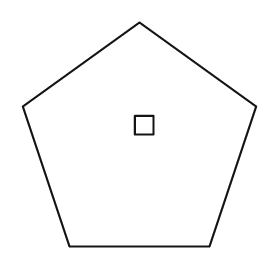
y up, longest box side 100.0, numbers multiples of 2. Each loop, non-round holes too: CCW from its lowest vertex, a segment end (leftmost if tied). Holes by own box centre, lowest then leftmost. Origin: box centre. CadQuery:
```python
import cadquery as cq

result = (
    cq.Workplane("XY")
    .moveTo(-30.0, -48.0)
    .lineTo(30.0, -48.0)
    .lineTo(50.0, 12.0)
    .lineTo(0.0, 48.0)
    .lineTo(-50.0, 12.0)
    .close()
    .moveTo(-2.0, 0.0)
    .lineTo(6.0, 0.0)
    .lineTo(6.0, 8.0)
    .lineTo(-2.0, 8.0)
    .close()
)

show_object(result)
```